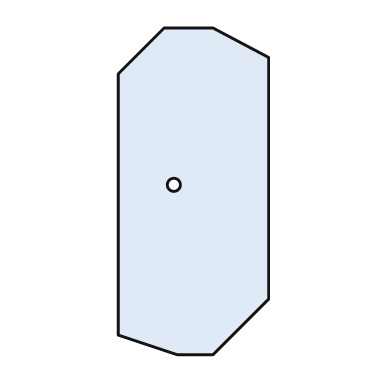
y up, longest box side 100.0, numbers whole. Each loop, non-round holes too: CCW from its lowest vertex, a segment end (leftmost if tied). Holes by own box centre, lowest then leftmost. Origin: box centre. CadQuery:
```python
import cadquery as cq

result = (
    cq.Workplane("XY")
    .moveTo(-5.0, -50.0)
    .lineTo(6.0, -50.0)
    .lineTo(23.0, -33.0)
    .lineTo(23.0, 41.0)
    .lineTo(6.0, 50.0)
    .lineTo(-9.0, 50.0)
    .lineTo(-23.0, 36.0)
    .lineTo(-23.0, -44.0)
    .close()
    .moveTo(-6.0, 2.0)
    .circle(2.0)
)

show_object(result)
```